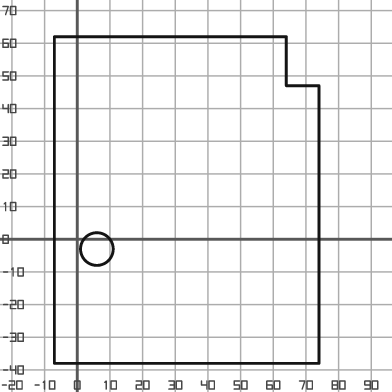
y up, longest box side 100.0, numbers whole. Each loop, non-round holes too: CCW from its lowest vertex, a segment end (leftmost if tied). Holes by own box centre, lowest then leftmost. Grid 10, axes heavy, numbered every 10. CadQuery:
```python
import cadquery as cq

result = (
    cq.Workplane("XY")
    .moveTo(-7.0, -38.0)
    .lineTo(74.0, -38.0)
    .lineTo(74.0, 47.0)
    .lineTo(64.0, 47.0)
    .lineTo(64.0, 62.0)
    .lineTo(-7.0, 62.0)
    .close()
    .moveTo(6.0, -3.0)
    .circle(5.0)
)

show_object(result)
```